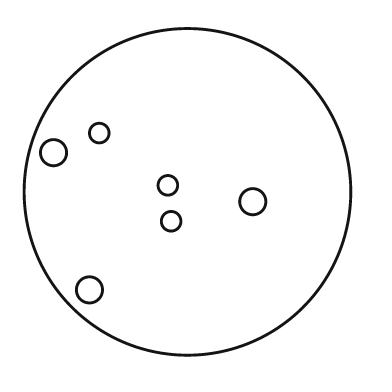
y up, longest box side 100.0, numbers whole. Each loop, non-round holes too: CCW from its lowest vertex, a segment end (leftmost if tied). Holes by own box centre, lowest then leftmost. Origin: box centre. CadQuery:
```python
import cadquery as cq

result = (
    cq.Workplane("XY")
    .moveTo(0.0, 0.0)
    .circle(50.0)
    .moveTo(-30.0, -30.0)
    .circle(4.0)
    .moveTo(-5.0, -9.0)
    .circle(3.0)
    .moveTo(20.0, -3.0)
    .circle(4.0)
    .moveTo(-6.0, 2.0)
    .circle(3.0)
    .moveTo(-41.0, 12.0)
    .circle(4.0)
    .moveTo(-27.0, 18.0)
    .circle(3.0)
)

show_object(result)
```